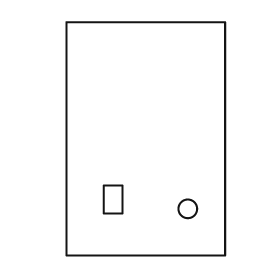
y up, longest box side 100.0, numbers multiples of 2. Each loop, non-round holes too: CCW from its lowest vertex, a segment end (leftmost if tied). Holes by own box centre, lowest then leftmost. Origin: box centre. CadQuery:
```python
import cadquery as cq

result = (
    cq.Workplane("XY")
    .moveTo(-34.0, -50.0)
    .lineTo(34.0, -50.0)
    .lineTo(34.0, 50.0)
    .lineTo(-34.0, 50.0)
    .close()
    .moveTo(18.0, -30.0)
    .circle(4.0)
    .moveTo(-18.0, -32.0)
    .lineTo(-10.0, -32.0)
    .lineTo(-10.0, -20.0)
    .lineTo(-18.0, -20.0)
    .close()
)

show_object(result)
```